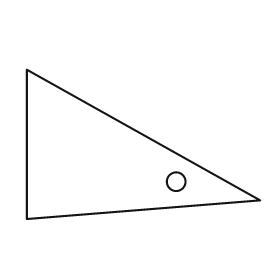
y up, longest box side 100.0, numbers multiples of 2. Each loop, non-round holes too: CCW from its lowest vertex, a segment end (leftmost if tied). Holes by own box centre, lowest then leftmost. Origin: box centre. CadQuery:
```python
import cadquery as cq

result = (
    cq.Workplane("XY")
    .moveTo(-50.0, -32.0)
    .lineTo(50.0, -24.0)
    .lineTo(-50.0, 32.0)
    .close()
    .moveTo(14.0, -16.0)
    .circle(4.0)
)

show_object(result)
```